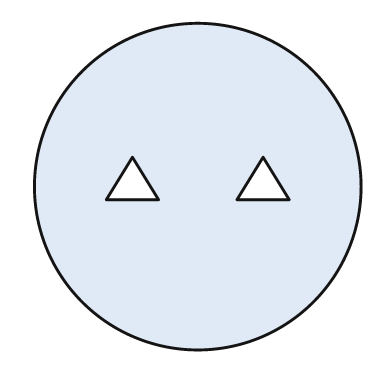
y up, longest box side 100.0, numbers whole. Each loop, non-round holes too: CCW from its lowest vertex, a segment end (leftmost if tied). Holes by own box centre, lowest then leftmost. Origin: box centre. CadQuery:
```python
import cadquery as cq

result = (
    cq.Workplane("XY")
    .moveTo(0.0, 0.0)
    .circle(50.0)
    .moveTo(-28.0, -4.0)
    .lineTo(-12.0, -4.0)
    .lineTo(-20.0, 9.0)
    .close()
    .moveTo(12.0, -4.0)
    .lineTo(28.0, -4.0)
    .lineTo(20.0, 9.0)
    .close()
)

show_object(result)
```